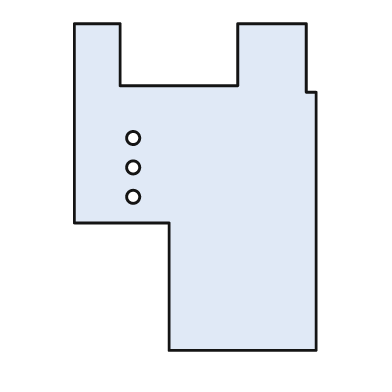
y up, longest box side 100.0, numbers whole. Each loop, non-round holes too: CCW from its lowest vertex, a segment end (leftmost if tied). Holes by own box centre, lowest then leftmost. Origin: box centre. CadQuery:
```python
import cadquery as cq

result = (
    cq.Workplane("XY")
    .moveTo(-8.0, -50.0)
    .lineTo(37.0, -50.0)
    .lineTo(37.0, 29.0)
    .lineTo(34.0, 29.0)
    .lineTo(34.0, 50.0)
    .lineTo(13.0, 50.0)
    .lineTo(13.0, 31.0)
    .lineTo(-23.0, 31.0)
    .lineTo(-23.0, 50.0)
    .lineTo(-37.0, 50.0)
    .lineTo(-37.0, -11.0)
    .lineTo(-8.0, -11.0)
    .close()
    .moveTo(-19.0, -3.0)
    .circle(2.0)
    .moveTo(-19.0, 6.0)
    .circle(2.0)
    .moveTo(-19.0, 15.0)
    .circle(2.0)
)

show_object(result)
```